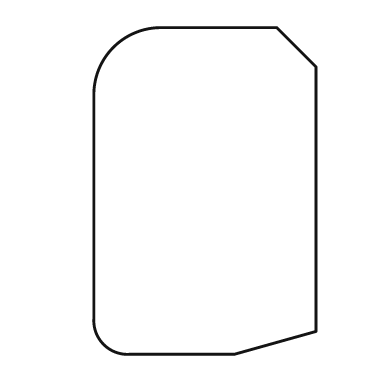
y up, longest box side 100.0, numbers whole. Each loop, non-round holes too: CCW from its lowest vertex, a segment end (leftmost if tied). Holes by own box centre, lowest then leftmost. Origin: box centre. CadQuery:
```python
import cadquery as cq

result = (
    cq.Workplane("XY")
    .moveTo(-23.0, -50.0)
    .lineTo(9.0, -50.0)
    .lineTo(34.0, -43.0)
    .lineTo(34.0, 38.0)
    .lineTo(22.0, 50.0)
    .lineTo(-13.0, 50.0)
    .threePointArc((-28.0, 44.0), (-34.0, 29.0))
    .lineTo(-34.0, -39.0)
    .threePointArc((-31.0, -47.0), (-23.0, -50.0))
    .close()
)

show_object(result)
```